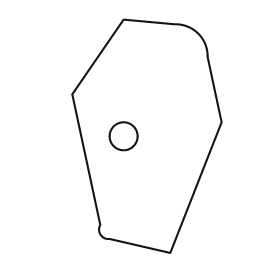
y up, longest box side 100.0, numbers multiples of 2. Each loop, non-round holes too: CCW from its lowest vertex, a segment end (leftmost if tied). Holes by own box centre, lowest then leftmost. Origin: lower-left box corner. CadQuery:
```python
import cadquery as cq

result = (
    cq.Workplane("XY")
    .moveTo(42.0, 0.0)
    .lineTo(64.0, 56.0)
    .lineTo(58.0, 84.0)
    .threePointArc((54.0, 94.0), (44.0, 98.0))
    .lineTo(22.0, 100.0)
    .lineTo(0.0, 68.0)
    .lineTo(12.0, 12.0)
    .threePointArc((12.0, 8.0), (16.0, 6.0))
    .close()
    .moveTo(22.0, 50.0)
    .circle(6.0)
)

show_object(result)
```